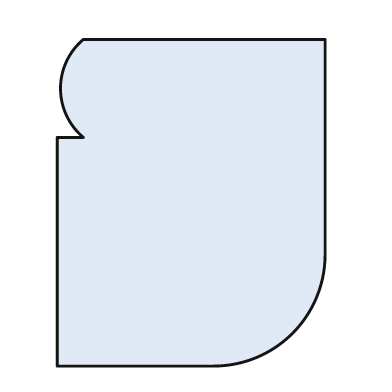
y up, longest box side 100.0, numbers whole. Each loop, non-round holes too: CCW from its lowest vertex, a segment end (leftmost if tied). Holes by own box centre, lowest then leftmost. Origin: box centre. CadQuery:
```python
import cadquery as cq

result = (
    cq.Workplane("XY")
    .moveTo(-41.0, -50.0)
    .lineTo(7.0, -50.0)
    .threePointArc((31.0, -40.0), (41.0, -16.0))
    .lineTo(41.0, 50.0)
    .lineTo(-33.0, 50.0)
    .threePointArc((-40.0, 35.0), (-33.0, 20.0))
    .lineTo(-41.0, 20.0)
    .close()
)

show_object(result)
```